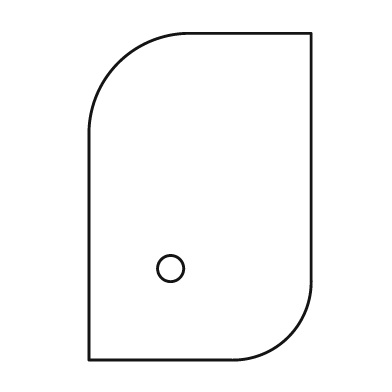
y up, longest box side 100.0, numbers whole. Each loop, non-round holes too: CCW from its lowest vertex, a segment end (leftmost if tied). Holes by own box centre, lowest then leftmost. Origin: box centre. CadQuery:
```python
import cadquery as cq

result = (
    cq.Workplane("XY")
    .moveTo(-34.0, -50.0)
    .lineTo(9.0, -50.0)
    .threePointArc((27.0, -43.0), (34.0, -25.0))
    .lineTo(34.0, 50.0)
    .lineTo(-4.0, 50.0)
    .threePointArc((-25.0, 41.0), (-34.0, 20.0))
    .close()
    .moveTo(-9.0, -22.0)
    .circle(4.0)
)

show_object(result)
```